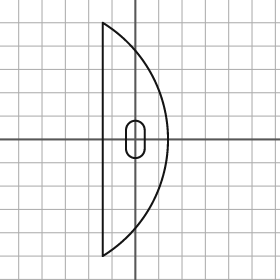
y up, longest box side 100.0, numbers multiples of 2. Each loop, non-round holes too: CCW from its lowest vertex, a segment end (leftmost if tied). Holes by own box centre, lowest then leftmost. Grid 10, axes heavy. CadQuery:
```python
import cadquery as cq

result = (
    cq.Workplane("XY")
    .moveTo(-14.0, -50.0)
    .threePointArc((14.0, 0.0), (-14.0, 50.0))
    .close()
    .moveTo(-4.0, -4.0)
    .threePointArc((0.0, -8.0), (4.0, -4.0))
    .lineTo(4.0, 4.0)
    .threePointArc((0.0, 8.0), (-4.0, 4.0))
    .close()
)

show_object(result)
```